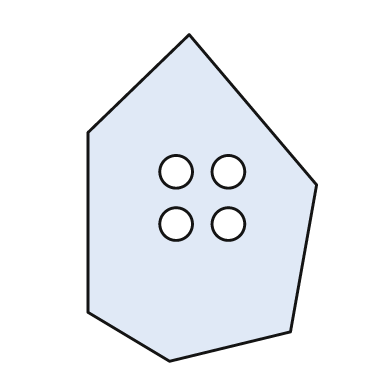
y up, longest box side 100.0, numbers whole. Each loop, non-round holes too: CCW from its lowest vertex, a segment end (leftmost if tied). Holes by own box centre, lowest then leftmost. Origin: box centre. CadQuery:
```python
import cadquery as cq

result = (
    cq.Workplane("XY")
    .moveTo(-10.0, -50.0)
    .lineTo(27.0, -41.0)
    .lineTo(35.0, 4.0)
    .lineTo(-4.0, 50.0)
    .lineTo(-35.0, 20.0)
    .lineTo(-35.0, -35.0)
    .close()
    .moveTo(-8.0, -8.0)
    .circle(5.0)
    .moveTo(8.0, -8.0)
    .circle(5.0)
    .moveTo(-8.0, 8.0)
    .circle(5.0)
    .moveTo(8.0, 8.0)
    .circle(5.0)
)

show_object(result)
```